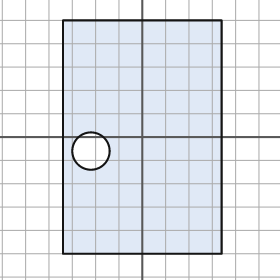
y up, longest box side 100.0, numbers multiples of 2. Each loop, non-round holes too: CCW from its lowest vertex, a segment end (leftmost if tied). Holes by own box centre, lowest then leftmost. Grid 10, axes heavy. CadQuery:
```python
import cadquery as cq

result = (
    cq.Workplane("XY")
    .moveTo(-34.0, -50.0)
    .lineTo(34.0, -50.0)
    .lineTo(34.0, 50.0)
    .lineTo(-34.0, 50.0)
    .close()
    .moveTo(-22.0, -6.0)
    .circle(8.0)
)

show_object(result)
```